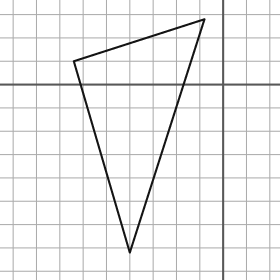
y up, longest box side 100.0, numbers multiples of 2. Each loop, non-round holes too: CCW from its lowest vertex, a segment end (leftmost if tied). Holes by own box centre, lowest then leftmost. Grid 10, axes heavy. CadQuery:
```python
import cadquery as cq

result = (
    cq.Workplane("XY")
    .moveTo(-40.0, -72.0)
    .lineTo(-8.0, 28.0)
    .lineTo(-64.0, 10.0)
    .close()
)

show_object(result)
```